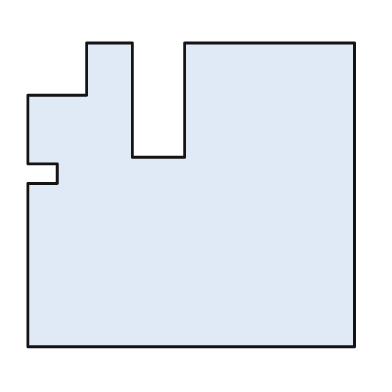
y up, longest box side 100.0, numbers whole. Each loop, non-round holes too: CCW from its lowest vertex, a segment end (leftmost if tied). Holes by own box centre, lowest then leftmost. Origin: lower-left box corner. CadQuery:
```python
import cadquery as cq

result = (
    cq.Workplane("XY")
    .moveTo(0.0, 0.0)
    .lineTo(100.0, 0.0)
    .lineTo(100.0, 93.0)
    .lineTo(48.0, 93.0)
    .lineTo(48.0, 58.0)
    .lineTo(32.0, 58.0)
    .lineTo(32.0, 93.0)
    .lineTo(18.0, 93.0)
    .lineTo(18.0, 77.0)
    .lineTo(0.0, 77.0)
    .lineTo(0.0, 56.0)
    .lineTo(9.0, 56.0)
    .lineTo(9.0, 50.0)
    .lineTo(0.0, 50.0)
    .close()
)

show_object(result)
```